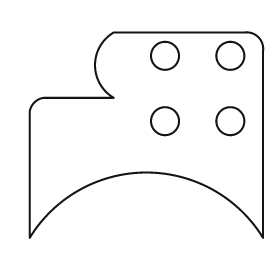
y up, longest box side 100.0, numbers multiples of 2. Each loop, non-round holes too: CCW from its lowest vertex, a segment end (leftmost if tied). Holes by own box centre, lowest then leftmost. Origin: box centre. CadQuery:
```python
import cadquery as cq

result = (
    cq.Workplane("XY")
    .moveTo(-50.0, -44.0)
    .threePointArc((0.0, -16.0), (50.0, -44.0))
    .lineTo(50.0, 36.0)
    .threePointArc((48.0, 42.0), (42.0, 44.0))
    .lineTo(-14.0, 44.0)
    .threePointArc((-22.0, 30.0), (-14.0, 16.0))
    .lineTo(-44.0, 16.0)
    .threePointArc((-48.0, 14.0), (-50.0, 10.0))
    .close()
    .moveTo(8.0, 6.0)
    .circle(6.0)
    .moveTo(36.0, 6.0)
    .circle(6.0)
    .moveTo(8.0, 34.0)
    .circle(6.0)
    .moveTo(36.0, 34.0)
    .circle(6.0)
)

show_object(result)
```